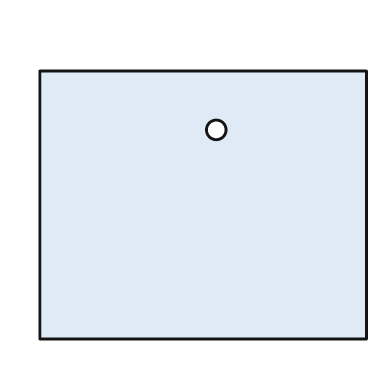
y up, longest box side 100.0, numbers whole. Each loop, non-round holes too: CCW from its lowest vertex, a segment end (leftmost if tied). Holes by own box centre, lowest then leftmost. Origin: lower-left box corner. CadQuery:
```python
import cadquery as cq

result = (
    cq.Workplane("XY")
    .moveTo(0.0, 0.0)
    .lineTo(100.0, 0.0)
    .lineTo(100.0, 82.0)
    .lineTo(0.0, 82.0)
    .close()
    .moveTo(54.0, 64.0)
    .circle(3.0)
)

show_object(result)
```